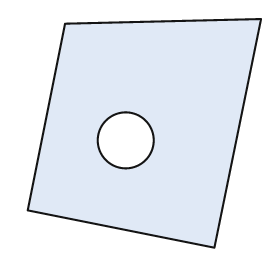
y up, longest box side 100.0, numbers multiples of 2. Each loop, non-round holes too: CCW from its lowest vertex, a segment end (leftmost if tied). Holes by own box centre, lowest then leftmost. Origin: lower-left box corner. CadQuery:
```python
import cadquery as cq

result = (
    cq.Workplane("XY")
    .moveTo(80.0, 0.0)
    .lineTo(100.0, 98.0)
    .lineTo(16.0, 96.0)
    .lineTo(0.0, 16.0)
    .close()
    .moveTo(42.0, 46.0)
    .circle(12.0)
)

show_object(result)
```